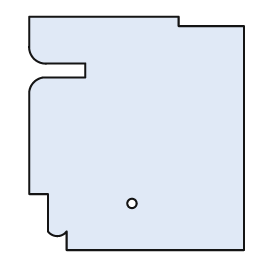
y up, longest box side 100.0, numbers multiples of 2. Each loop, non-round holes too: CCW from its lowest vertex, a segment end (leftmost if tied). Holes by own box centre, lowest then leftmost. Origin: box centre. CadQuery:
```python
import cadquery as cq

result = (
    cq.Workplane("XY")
    .moveTo(-30.0, -50.0)
    .lineTo(46.0, -50.0)
    .lineTo(46.0, 46.0)
    .lineTo(18.0, 46.0)
    .lineTo(18.0, 50.0)
    .lineTo(-46.0, 50.0)
    .lineTo(-46.0, 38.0)
    .threePointArc((-44.0, 32.0), (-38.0, 30.0))
    .lineTo(-22.0, 30.0)
    .lineTo(-22.0, 24.0)
    .lineTo(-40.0, 24.0)
    .threePointArc((-44.0, 22.0), (-46.0, 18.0))
    .lineTo(-46.0, -26.0)
    .lineTo(-38.0, -26.0)
    .lineTo(-38.0, -42.0)
    .threePointArc((-34.0, -44.0), (-30.0, -42.0))
    .close()
    .moveTo(-2.0, -30.0)
    .circle(2.0)
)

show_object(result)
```